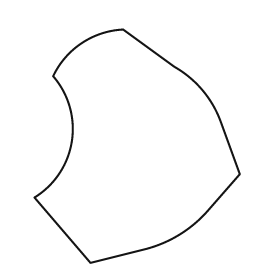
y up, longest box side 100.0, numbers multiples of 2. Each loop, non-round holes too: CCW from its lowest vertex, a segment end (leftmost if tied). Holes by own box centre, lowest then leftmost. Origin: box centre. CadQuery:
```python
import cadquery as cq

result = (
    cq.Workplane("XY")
    .moveTo(-20.0, -50.0)
    .lineTo(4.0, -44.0)
    .threePointArc((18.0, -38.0), (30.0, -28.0))
    .lineTo(44.0, -12.0)
    .lineTo(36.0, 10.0)
    .threePointArc((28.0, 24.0), (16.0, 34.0))
    .lineTo(-6.0, 50.0)
    .threePointArc((-24.0, 44.0), (-36.0, 30.0))
    .threePointArc((-28.0, 2.0), (-44.0, -22.0))
    .close()
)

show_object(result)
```